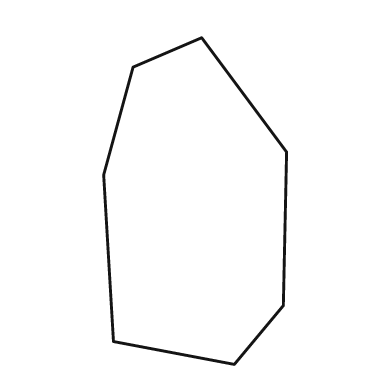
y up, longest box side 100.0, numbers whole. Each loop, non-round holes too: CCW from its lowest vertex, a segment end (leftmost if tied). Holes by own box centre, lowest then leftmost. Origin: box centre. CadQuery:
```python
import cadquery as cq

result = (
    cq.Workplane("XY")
    .moveTo(12.0, -50.0)
    .lineTo(27.0, -32.0)
    .lineTo(28.0, 15.0)
    .lineTo(2.0, 50.0)
    .lineTo(-19.0, 41.0)
    .lineTo(-28.0, 8.0)
    .lineTo(-25.0, -43.0)
    .close()
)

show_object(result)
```